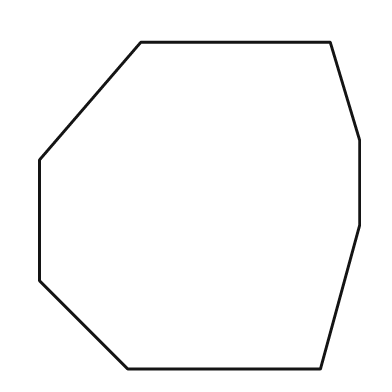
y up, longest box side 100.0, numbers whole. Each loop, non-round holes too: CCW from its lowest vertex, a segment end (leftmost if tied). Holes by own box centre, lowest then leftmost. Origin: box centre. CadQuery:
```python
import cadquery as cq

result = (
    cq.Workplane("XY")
    .moveTo(-22.0, -50.0)
    .lineTo(37.0, -50.0)
    .lineTo(49.0, -6.0)
    .lineTo(49.0, 20.0)
    .lineTo(40.0, 50.0)
    .lineTo(-18.0, 50.0)
    .lineTo(-49.0, 14.0)
    .lineTo(-49.0, -23.0)
    .close()
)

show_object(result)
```